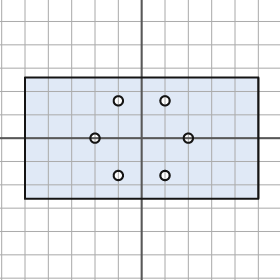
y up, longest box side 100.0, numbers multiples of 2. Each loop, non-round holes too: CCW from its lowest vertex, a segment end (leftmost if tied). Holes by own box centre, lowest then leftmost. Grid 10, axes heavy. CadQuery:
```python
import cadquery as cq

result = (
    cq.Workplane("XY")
    .moveTo(-50.0, -26.0)
    .lineTo(50.0, -26.0)
    .lineTo(50.0, 26.0)
    .lineTo(-50.0, 26.0)
    .close()
    .moveTo(-10.0, -16.0)
    .circle(2.0)
    .moveTo(10.0, -16.0)
    .circle(2.0)
    .moveTo(-20.0, 0.0)
    .circle(2.0)
    .moveTo(20.0, 0.0)
    .circle(2.0)
    .moveTo(-10.0, 16.0)
    .circle(2.0)
    .moveTo(10.0, 16.0)
    .circle(2.0)
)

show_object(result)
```